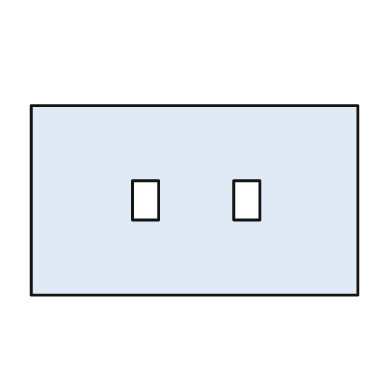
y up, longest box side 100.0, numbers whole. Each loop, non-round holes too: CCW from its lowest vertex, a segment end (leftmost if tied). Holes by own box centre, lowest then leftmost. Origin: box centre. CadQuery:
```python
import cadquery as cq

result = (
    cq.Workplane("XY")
    .moveTo(-50.0, -29.0)
    .lineTo(50.0, -29.0)
    .lineTo(50.0, 29.0)
    .lineTo(-50.0, 29.0)
    .close()
    .moveTo(-19.0, -6.0)
    .lineTo(-11.0, -6.0)
    .lineTo(-11.0, 6.0)
    .lineTo(-19.0, 6.0)
    .close()
    .moveTo(12.0, -6.0)
    .lineTo(20.0, -6.0)
    .lineTo(20.0, 6.0)
    .lineTo(12.0, 6.0)
    .close()
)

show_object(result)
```